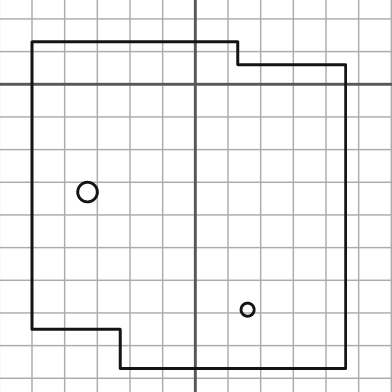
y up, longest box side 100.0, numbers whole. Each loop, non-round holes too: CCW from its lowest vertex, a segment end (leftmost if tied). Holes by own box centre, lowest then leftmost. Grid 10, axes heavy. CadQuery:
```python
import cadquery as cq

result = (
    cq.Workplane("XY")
    .moveTo(-23.0, -87.0)
    .lineTo(46.0, -87.0)
    .lineTo(46.0, 6.0)
    .lineTo(13.0, 6.0)
    .lineTo(13.0, 13.0)
    .lineTo(-50.0, 13.0)
    .lineTo(-50.0, -75.0)
    .lineTo(-23.0, -75.0)
    .close()
    .moveTo(16.0, -69.0)
    .circle(2.0)
    .moveTo(-33.0, -33.0)
    .circle(3.0)
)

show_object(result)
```